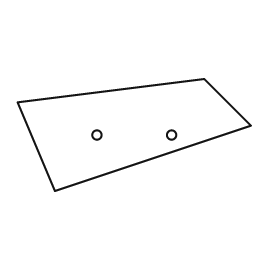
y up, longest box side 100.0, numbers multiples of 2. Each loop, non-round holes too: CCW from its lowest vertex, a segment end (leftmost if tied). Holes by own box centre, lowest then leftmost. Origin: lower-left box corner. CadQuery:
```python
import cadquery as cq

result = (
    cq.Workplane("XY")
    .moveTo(16.0, 0.0)
    .lineTo(100.0, 28.0)
    .lineTo(80.0, 48.0)
    .lineTo(0.0, 38.0)
    .close()
    .moveTo(34.0, 24.0)
    .circle(2.0)
    .moveTo(66.0, 24.0)
    .circle(2.0)
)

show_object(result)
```